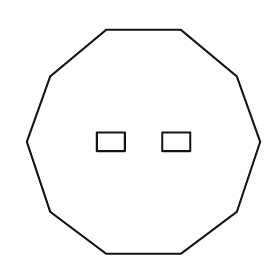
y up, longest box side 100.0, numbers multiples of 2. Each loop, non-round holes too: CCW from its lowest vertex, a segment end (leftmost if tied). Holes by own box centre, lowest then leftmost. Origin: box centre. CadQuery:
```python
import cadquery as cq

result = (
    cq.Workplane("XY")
    .moveTo(-16.0, -48.0)
    .lineTo(16.0, -48.0)
    .lineTo(40.0, -30.0)
    .lineTo(50.0, 0.0)
    .lineTo(40.0, 28.0)
    .lineTo(16.0, 48.0)
    .lineTo(-16.0, 48.0)
    .lineTo(-40.0, 28.0)
    .lineTo(-50.0, 0.0)
    .lineTo(-40.0, -30.0)
    .close()
    .moveTo(-20.0, -4.0)
    .lineTo(-8.0, -4.0)
    .lineTo(-8.0, 4.0)
    .lineTo(-20.0, 4.0)
    .close()
    .moveTo(8.0, -4.0)
    .lineTo(20.0, -4.0)
    .lineTo(20.0, 4.0)
    .lineTo(8.0, 4.0)
    .close()
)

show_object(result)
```